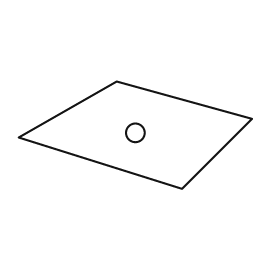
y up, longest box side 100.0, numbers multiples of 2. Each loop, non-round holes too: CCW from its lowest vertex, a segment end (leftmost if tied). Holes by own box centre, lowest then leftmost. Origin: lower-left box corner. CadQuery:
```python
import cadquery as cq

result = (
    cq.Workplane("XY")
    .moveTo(70.0, 0.0)
    .lineTo(100.0, 30.0)
    .lineTo(42.0, 46.0)
    .lineTo(0.0, 22.0)
    .close()
    .moveTo(50.0, 24.0)
    .circle(4.0)
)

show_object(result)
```